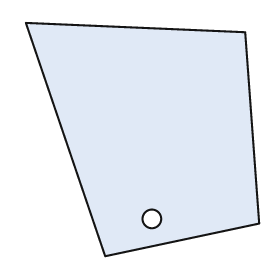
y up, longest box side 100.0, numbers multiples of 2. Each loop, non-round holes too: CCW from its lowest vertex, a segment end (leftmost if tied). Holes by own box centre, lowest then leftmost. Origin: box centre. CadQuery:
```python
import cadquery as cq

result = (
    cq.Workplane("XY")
    .moveTo(-16.0, -50.0)
    .lineTo(50.0, -36.0)
    .lineTo(44.0, 46.0)
    .lineTo(-50.0, 50.0)
    .close()
    .moveTo(4.0, -34.0)
    .circle(4.0)
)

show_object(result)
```